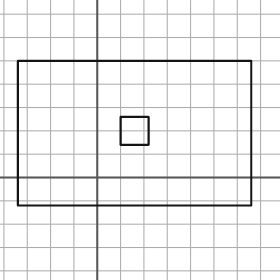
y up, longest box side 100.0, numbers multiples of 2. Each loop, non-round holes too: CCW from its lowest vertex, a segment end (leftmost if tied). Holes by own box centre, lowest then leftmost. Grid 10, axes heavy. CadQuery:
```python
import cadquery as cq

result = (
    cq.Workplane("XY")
    .moveTo(-34.0, -12.0)
    .lineTo(66.0, -12.0)
    .lineTo(66.0, 50.0)
    .lineTo(-34.0, 50.0)
    .close()
    .moveTo(10.0, 14.0)
    .lineTo(22.0, 14.0)
    .lineTo(22.0, 26.0)
    .lineTo(10.0, 26.0)
    .close()
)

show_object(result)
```